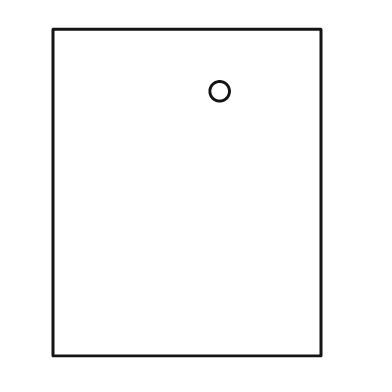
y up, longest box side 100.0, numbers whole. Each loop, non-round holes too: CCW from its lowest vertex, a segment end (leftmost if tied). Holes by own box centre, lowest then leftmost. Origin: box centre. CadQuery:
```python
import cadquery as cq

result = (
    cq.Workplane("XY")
    .moveTo(-41.0, -50.0)
    .lineTo(41.0, -50.0)
    .lineTo(41.0, 50.0)
    .lineTo(-41.0, 50.0)
    .close()
    .moveTo(10.0, 31.0)
    .circle(3.0)
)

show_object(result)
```